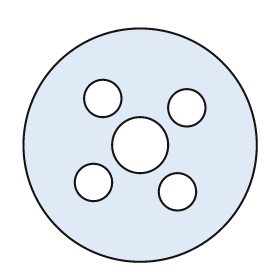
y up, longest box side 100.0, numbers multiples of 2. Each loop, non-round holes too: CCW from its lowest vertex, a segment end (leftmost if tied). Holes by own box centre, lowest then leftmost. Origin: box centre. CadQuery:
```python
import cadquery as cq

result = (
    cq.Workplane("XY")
    .moveTo(0.0, 0.0)
    .circle(50.0)
    .moveTo(16.0, -20.0)
    .circle(8.0)
    .moveTo(-20.0, -16.0)
    .circle(8.0)
    .moveTo(0.0, 0.0)
    .circle(12.0)
    .moveTo(20.0, 16.0)
    .circle(8.0)
    .moveTo(-16.0, 20.0)
    .circle(8.0)
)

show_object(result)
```